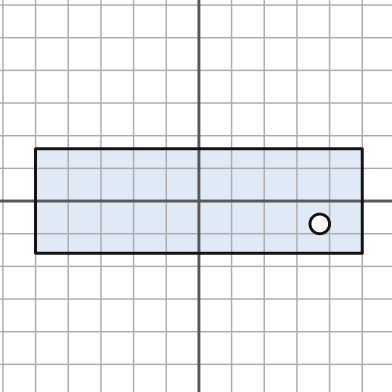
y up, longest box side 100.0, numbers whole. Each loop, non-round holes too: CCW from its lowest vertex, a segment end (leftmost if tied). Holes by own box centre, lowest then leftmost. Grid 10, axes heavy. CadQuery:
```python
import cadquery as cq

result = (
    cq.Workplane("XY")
    .moveTo(-50.0, -16.0)
    .lineTo(50.0, -16.0)
    .lineTo(50.0, 16.0)
    .lineTo(-50.0, 16.0)
    .close()
    .moveTo(37.0, -7.0)
    .circle(3.0)
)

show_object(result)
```